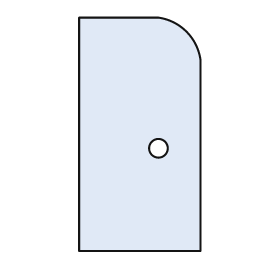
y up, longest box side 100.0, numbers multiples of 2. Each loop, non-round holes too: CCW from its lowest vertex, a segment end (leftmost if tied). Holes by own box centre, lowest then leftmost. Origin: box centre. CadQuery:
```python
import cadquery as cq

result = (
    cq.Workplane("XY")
    .moveTo(-26.0, -50.0)
    .lineTo(26.0, -50.0)
    .lineTo(26.0, 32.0)
    .threePointArc((20.0, 44.0), (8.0, 50.0))
    .lineTo(-26.0, 50.0)
    .close()
    .moveTo(8.0, -6.0)
    .circle(4.0)
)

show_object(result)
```